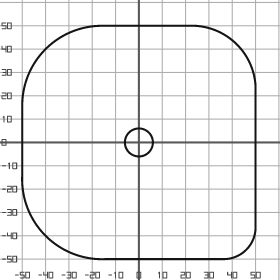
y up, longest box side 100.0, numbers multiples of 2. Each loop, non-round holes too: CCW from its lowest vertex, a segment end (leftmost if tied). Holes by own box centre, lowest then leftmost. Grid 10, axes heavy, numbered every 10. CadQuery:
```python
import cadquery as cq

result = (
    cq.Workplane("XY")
    .moveTo(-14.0, -50.0)
    .lineTo(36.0, -50.0)
    .threePointArc((46.0, -46.0), (50.0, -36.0))
    .lineTo(50.0, 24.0)
    .threePointArc((42.0, 42.0), (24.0, 50.0))
    .lineTo(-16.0, 50.0)
    .threePointArc((-40.0, 40.0), (-50.0, 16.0))
    .lineTo(-50.0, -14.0)
    .threePointArc((-40.0, -40.0), (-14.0, -50.0))
    .close()
    .moveTo(0.0, 0.0)
    .circle(6.0)
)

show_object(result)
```